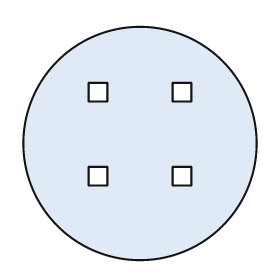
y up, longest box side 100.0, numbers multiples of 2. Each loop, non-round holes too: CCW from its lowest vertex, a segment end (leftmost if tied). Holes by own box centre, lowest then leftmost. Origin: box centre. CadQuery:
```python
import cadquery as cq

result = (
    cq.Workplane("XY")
    .moveTo(0.0, 0.0)
    .circle(50.0)
    .moveTo(-22.0, -18.0)
    .lineTo(-14.0, -18.0)
    .lineTo(-14.0, -10.0)
    .lineTo(-22.0, -10.0)
    .close()
    .moveTo(14.0, -18.0)
    .lineTo(22.0, -18.0)
    .lineTo(22.0, -10.0)
    .lineTo(14.0, -10.0)
    .close()
    .moveTo(-22.0, 18.0)
    .lineTo(-14.0, 18.0)
    .lineTo(-14.0, 26.0)
    .lineTo(-22.0, 26.0)
    .close()
    .moveTo(14.0, 18.0)
    .lineTo(22.0, 18.0)
    .lineTo(22.0, 26.0)
    .lineTo(14.0, 26.0)
    .close()
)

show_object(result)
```